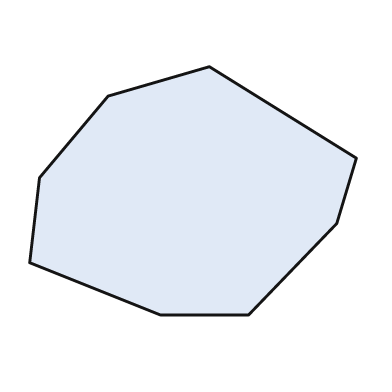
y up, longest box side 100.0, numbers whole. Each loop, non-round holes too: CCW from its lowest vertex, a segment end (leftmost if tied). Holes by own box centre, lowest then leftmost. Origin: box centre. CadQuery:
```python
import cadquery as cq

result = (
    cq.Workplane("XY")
    .moveTo(-10.0, -38.0)
    .lineTo(17.0, -38.0)
    .lineTo(44.0, -10.0)
    .lineTo(50.0, 10.0)
    .lineTo(5.0, 38.0)
    .lineTo(-26.0, 29.0)
    .lineTo(-47.0, 4.0)
    .lineTo(-50.0, -22.0)
    .close()
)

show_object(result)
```